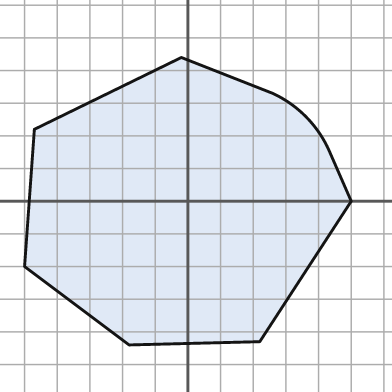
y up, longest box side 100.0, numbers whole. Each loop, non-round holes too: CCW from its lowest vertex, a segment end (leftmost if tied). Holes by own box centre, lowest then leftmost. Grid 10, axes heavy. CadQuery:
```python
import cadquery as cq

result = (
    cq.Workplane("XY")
    .moveTo(-18.0, -44.0)
    .lineTo(22.0, -43.0)
    .lineTo(50.0, 0.0)
    .lineTo(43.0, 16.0)
    .threePointArc((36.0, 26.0), (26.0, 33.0))
    .lineTo(-2.0, 44.0)
    .lineTo(-47.0, 22.0)
    .lineTo(-50.0, -20.0)
    .close()
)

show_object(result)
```